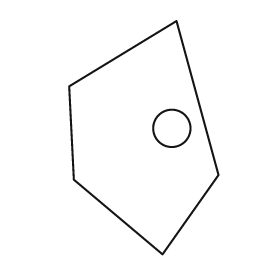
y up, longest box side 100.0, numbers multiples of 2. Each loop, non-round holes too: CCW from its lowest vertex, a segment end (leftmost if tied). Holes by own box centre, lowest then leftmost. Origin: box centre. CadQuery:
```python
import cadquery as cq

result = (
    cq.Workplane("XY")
    .moveTo(8.0, -50.0)
    .lineTo(32.0, -16.0)
    .lineTo(14.0, 50.0)
    .lineTo(-32.0, 22.0)
    .lineTo(-30.0, -18.0)
    .close()
    .moveTo(12.0, 4.0)
    .circle(8.0)
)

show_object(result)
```